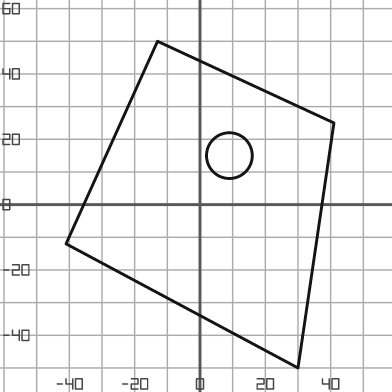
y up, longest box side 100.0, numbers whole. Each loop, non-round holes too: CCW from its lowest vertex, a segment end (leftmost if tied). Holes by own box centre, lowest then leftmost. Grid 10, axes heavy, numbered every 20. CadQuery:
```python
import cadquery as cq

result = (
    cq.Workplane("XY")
    .moveTo(30.0, -50.0)
    .lineTo(41.0, 25.0)
    .lineTo(-13.0, 50.0)
    .lineTo(-41.0, -12.0)
    .close()
    .moveTo(9.0, 15.0)
    .circle(7.0)
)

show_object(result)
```